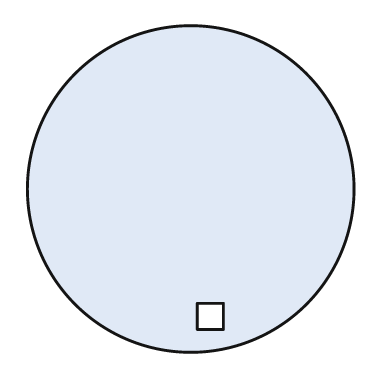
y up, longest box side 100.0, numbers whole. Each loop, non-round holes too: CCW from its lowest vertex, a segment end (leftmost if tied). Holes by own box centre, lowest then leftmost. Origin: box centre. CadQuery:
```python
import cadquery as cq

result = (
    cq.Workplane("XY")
    .moveTo(0.0, 0.0)
    .circle(50.0)
    .moveTo(2.0, -43.0)
    .lineTo(10.0, -43.0)
    .lineTo(10.0, -35.0)
    .lineTo(2.0, -35.0)
    .close()
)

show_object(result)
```